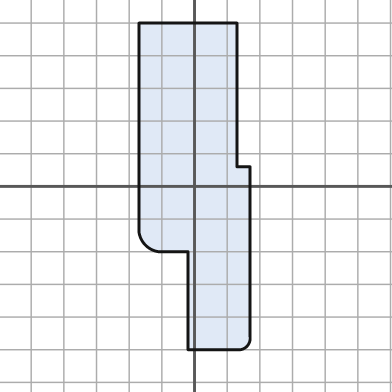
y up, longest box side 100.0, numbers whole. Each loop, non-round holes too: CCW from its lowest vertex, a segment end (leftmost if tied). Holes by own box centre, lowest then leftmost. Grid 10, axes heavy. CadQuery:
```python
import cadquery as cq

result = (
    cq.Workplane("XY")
    .moveTo(-2.0, -50.0)
    .lineTo(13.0, -50.0)
    .threePointArc((16.0, -49.0), (17.0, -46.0))
    .lineTo(17.0, 6.0)
    .lineTo(13.0, 6.0)
    .lineTo(13.0, 50.0)
    .lineTo(-17.0, 50.0)
    .lineTo(-17.0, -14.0)
    .threePointArc((-15.0, -18.0), (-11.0, -20.0))
    .lineTo(-2.0, -20.0)
    .close()
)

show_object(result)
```